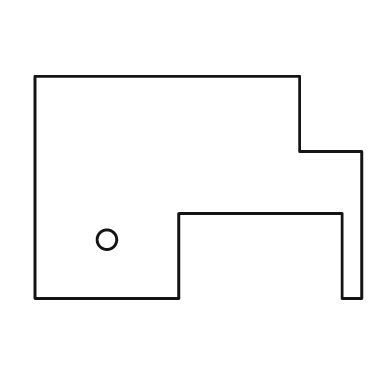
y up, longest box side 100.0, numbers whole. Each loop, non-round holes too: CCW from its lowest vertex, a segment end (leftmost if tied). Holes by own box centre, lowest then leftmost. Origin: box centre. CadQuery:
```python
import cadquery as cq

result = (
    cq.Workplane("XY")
    .moveTo(-50.0, -34.0)
    .lineTo(-6.0, -34.0)
    .lineTo(-6.0, -8.0)
    .lineTo(44.0, -8.0)
    .lineTo(44.0, -34.0)
    .lineTo(50.0, -34.0)
    .lineTo(50.0, 11.0)
    .lineTo(31.0, 11.0)
    .lineTo(31.0, 34.0)
    .lineTo(-50.0, 34.0)
    .close()
    .moveTo(-28.0, -16.0)
    .circle(3.0)
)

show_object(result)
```